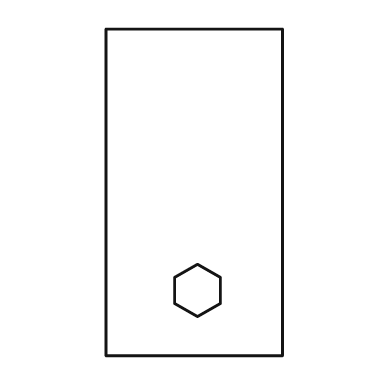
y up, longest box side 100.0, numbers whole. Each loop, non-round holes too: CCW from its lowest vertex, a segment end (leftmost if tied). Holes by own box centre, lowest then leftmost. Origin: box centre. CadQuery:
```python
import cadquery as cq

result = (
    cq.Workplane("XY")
    .moveTo(-27.0, -50.0)
    .lineTo(27.0, -50.0)
    .lineTo(27.0, 50.0)
    .lineTo(-27.0, 50.0)
    .close()
    .moveTo(1.0, -38.0)
    .lineTo(8.0, -34.0)
    .lineTo(8.0, -26.0)
    .lineTo(1.0, -22.0)
    .lineTo(-6.0, -26.0)
    .lineTo(-6.0, -34.0)
    .close()
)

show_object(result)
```